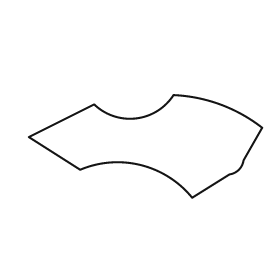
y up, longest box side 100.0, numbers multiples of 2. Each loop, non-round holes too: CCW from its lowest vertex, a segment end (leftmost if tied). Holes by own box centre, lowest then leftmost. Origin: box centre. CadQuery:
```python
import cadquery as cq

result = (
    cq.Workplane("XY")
    .moveTo(20.0, -22.0)
    .lineTo(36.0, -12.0)
    .threePointArc((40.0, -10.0), (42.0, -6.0))
    .lineTo(50.0, 8.0)
    .threePointArc((32.0, 18.0), (12.0, 22.0))
    .threePointArc((-4.0, 12.0), (-22.0, 18.0))
    .lineTo(-50.0, 4.0)
    .lineTo(-28.0, -10.0)
    .threePointArc((-2.0, -8.0), (20.0, -22.0))
    .close()
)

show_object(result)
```